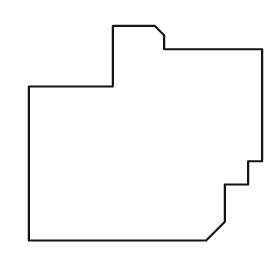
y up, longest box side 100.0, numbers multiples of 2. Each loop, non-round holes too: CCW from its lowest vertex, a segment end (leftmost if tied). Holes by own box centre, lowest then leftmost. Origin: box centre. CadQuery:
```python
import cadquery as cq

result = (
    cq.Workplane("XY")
    .moveTo(-50.0, -46.0)
    .lineTo(26.0, -46.0)
    .lineTo(34.0, -38.0)
    .lineTo(34.0, -22.0)
    .lineTo(44.0, -22.0)
    .lineTo(44.0, -12.0)
    .lineTo(50.0, -12.0)
    .lineTo(50.0, 36.0)
    .lineTo(8.0, 36.0)
    .lineTo(8.0, 42.0)
    .lineTo(4.0, 46.0)
    .lineTo(-14.0, 46.0)
    .lineTo(-14.0, 20.0)
    .lineTo(-50.0, 20.0)
    .close()
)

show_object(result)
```